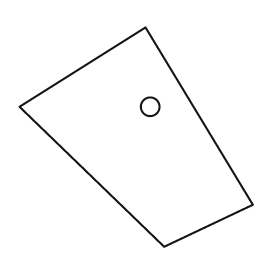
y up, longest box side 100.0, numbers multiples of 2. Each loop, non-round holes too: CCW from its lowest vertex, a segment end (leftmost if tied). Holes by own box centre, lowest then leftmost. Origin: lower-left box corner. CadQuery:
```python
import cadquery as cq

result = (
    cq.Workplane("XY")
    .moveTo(62.0, 0.0)
    .lineTo(100.0, 18.0)
    .lineTo(54.0, 94.0)
    .lineTo(0.0, 60.0)
    .close()
    .moveTo(56.0, 60.0)
    .circle(4.0)
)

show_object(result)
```